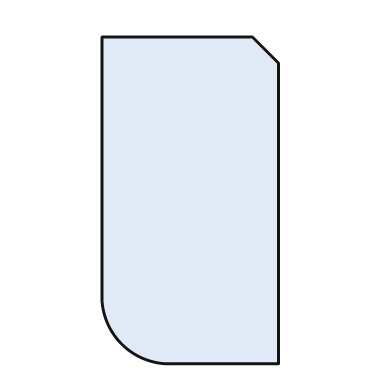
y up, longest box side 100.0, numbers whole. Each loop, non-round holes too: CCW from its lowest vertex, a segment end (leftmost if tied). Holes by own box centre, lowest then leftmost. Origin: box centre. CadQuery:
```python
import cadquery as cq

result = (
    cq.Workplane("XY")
    .moveTo(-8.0, -50.0)
    .lineTo(27.0, -50.0)
    .lineTo(27.0, 42.0)
    .lineTo(19.0, 50.0)
    .lineTo(-27.0, 50.0)
    .lineTo(-27.0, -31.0)
    .threePointArc((-21.0, -44.0), (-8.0, -50.0))
    .close()
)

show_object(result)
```